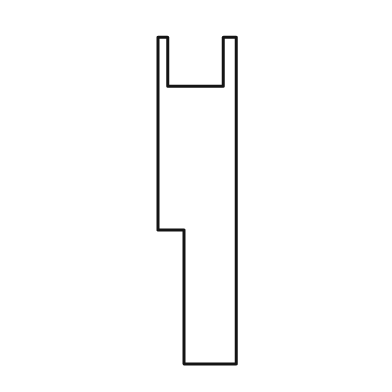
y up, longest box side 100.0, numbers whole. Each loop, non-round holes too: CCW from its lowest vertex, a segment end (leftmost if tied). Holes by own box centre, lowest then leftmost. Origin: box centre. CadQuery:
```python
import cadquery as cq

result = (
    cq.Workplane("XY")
    .moveTo(-4.0, -50.0)
    .lineTo(12.0, -50.0)
    .lineTo(12.0, 50.0)
    .lineTo(8.0, 50.0)
    .lineTo(8.0, 35.0)
    .lineTo(-9.0, 35.0)
    .lineTo(-9.0, 50.0)
    .lineTo(-12.0, 50.0)
    .lineTo(-12.0, -9.0)
    .lineTo(-4.0, -9.0)
    .close()
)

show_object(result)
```